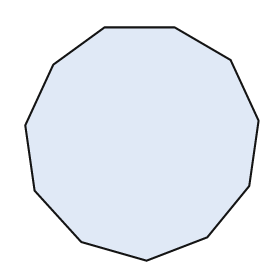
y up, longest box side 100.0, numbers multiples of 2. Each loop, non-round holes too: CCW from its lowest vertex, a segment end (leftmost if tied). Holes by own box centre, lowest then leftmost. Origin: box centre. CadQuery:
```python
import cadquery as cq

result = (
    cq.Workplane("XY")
    .moveTo(2.0, -50.0)
    .lineTo(28.0, -40.0)
    .lineTo(46.0, -18.0)
    .lineTo(50.0, 10.0)
    .lineTo(38.0, 36.0)
    .lineTo(14.0, 50.0)
    .lineTo(-16.0, 50.0)
    .lineTo(-38.0, 34.0)
    .lineTo(-50.0, 8.0)
    .lineTo(-46.0, -20.0)
    .lineTo(-26.0, -42.0)
    .close()
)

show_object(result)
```